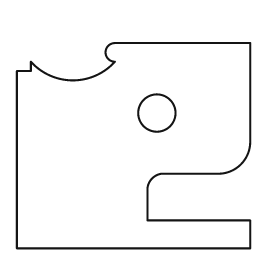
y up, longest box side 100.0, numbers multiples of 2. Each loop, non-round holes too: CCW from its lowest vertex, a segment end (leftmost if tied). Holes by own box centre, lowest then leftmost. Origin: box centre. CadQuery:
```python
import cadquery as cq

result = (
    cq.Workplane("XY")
    .moveTo(-50.0, -44.0)
    .lineTo(50.0, -44.0)
    .lineTo(50.0, -32.0)
    .lineTo(6.0, -32.0)
    .lineTo(6.0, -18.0)
    .threePointArc((8.0, -14.0), (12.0, -12.0))
    .lineTo(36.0, -12.0)
    .threePointArc((46.0, -8.0), (50.0, 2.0))
    .lineTo(50.0, 44.0)
    .lineTo(-8.0, 44.0)
    .threePointArc((-12.0, 40.0), (-8.0, 36.0))
    .threePointArc((-26.0, 28.0), (-44.0, 36.0))
    .lineTo(-44.0, 32.0)
    .lineTo(-50.0, 32.0)
    .close()
    .moveTo(10.0, 14.0)
    .circle(8.0)
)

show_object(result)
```